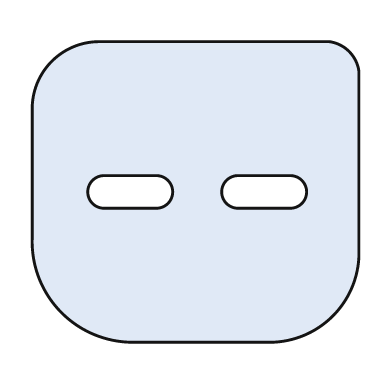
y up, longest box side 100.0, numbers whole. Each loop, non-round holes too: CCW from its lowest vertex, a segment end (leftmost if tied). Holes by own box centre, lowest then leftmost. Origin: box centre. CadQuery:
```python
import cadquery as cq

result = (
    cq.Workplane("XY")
    .moveTo(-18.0, -46.0)
    .lineTo(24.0, -46.0)
    .threePointArc((42.0, -38.0), (50.0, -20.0))
    .lineTo(50.0, 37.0)
    .threePointArc((47.0, 43.0), (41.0, 46.0))
    .lineTo(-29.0, 46.0)
    .threePointArc((-44.0, 40.0), (-50.0, 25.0))
    .lineTo(-50.0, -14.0)
    .threePointArc((-41.0, -37.0), (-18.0, -46.0))
    .close()
    .moveTo(-28.0, -5.0)
    .lineTo(-12.0, -5.0)
    .threePointArc((-7.0, 0.0), (-12.0, 5.0))
    .lineTo(-28.0, 5.0)
    .threePointArc((-33.0, 0.0), (-28.0, -5.0))
    .close()
    .moveTo(13.0, -5.0)
    .lineTo(29.0, -5.0)
    .threePointArc((34.0, 0.0), (29.0, 5.0))
    .lineTo(13.0, 5.0)
    .threePointArc((8.0, 0.0), (13.0, -5.0))
    .close()
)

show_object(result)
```